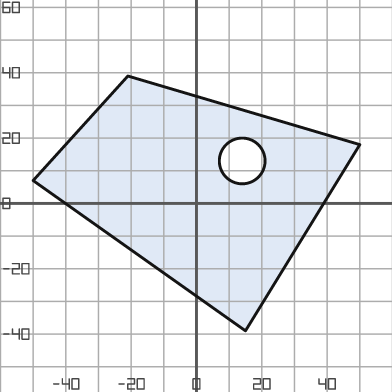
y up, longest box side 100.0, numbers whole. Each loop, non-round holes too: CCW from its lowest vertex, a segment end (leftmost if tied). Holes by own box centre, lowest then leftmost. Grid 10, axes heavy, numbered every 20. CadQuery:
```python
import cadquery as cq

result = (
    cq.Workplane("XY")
    .moveTo(15.0, -39.0)
    .lineTo(50.0, 18.0)
    .lineTo(-21.0, 39.0)
    .lineTo(-50.0, 7.0)
    .close()
    .moveTo(14.0, 13.0)
    .circle(7.0)
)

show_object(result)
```